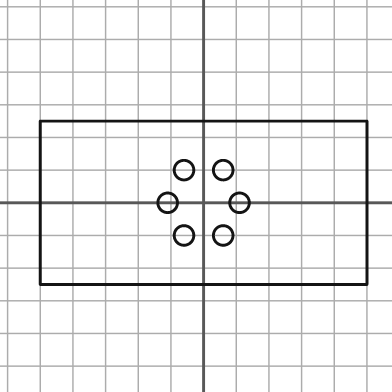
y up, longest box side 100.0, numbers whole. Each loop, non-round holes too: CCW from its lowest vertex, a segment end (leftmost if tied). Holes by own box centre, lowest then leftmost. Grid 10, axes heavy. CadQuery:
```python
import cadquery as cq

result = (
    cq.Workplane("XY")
    .moveTo(-50.0, -25.0)
    .lineTo(50.0, -25.0)
    .lineTo(50.0, 25.0)
    .lineTo(-50.0, 25.0)
    .close()
    .moveTo(-6.0, -10.0)
    .circle(3.0)
    .moveTo(6.0, -10.0)
    .circle(3.0)
    .moveTo(-11.0, 0.0)
    .circle(3.0)
    .moveTo(11.0, 0.0)
    .circle(3.0)
    .moveTo(-6.0, 10.0)
    .circle(3.0)
    .moveTo(6.0, 10.0)
    .circle(3.0)
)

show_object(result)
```